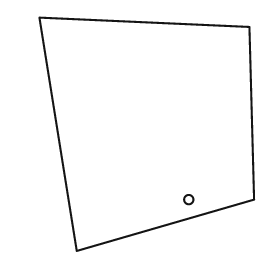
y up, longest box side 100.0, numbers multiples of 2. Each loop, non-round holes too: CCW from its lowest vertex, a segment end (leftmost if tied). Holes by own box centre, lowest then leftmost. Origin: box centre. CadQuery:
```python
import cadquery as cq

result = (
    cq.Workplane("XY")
    .moveTo(-30.0, -50.0)
    .lineTo(46.0, -28.0)
    .lineTo(44.0, 46.0)
    .lineTo(-46.0, 50.0)
    .close()
    .moveTo(18.0, -28.0)
    .circle(2.0)
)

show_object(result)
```